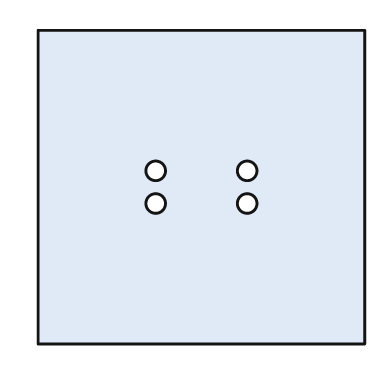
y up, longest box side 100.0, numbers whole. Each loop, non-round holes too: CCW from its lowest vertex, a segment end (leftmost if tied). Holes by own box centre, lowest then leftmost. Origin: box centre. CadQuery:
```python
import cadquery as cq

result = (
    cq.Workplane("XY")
    .moveTo(-50.0, -48.0)
    .lineTo(50.0, -48.0)
    .lineTo(50.0, 48.0)
    .lineTo(-50.0, 48.0)
    .close()
    .moveTo(-14.0, -5.0)
    .circle(3.0)
    .moveTo(14.0, -5.0)
    .circle(3.0)
    .moveTo(-14.0, 5.0)
    .circle(3.0)
    .moveTo(14.0, 5.0)
    .circle(3.0)
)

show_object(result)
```